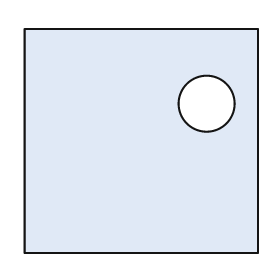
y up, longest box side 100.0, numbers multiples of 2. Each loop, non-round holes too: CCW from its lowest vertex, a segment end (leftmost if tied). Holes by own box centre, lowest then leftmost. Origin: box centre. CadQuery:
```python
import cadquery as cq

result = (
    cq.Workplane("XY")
    .moveTo(-50.0, -48.0)
    .lineTo(50.0, -48.0)
    .lineTo(50.0, 48.0)
    .lineTo(-50.0, 48.0)
    .close()
    .moveTo(28.0, 16.0)
    .circle(12.0)
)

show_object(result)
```